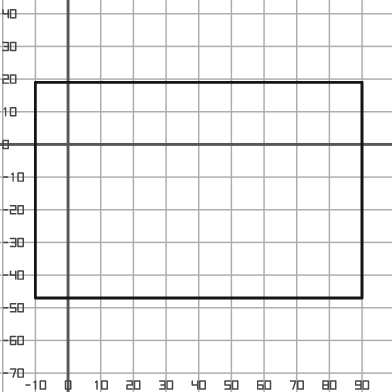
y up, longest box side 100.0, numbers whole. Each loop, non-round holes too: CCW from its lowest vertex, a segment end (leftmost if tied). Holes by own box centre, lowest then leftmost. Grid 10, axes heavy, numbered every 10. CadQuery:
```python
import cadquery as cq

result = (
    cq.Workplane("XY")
    .moveTo(-10.0, -47.0)
    .lineTo(90.0, -47.0)
    .lineTo(90.0, 19.0)
    .lineTo(-10.0, 19.0)
    .close()
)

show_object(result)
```